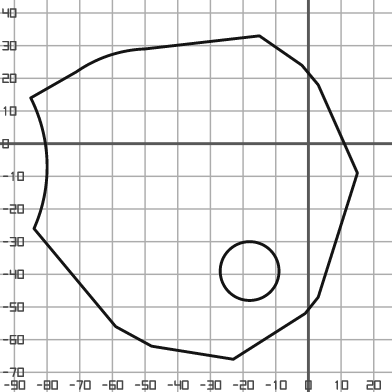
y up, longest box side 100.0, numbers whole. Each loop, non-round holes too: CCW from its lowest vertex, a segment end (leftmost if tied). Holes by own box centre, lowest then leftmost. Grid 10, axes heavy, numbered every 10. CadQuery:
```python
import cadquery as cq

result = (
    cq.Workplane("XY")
    .moveTo(-23.0, -66.0)
    .lineTo(-1.0, -52.0)
    .lineTo(3.0, -47.0)
    .lineTo(15.0, -9.0)
    .lineTo(3.0, 18.0)
    .lineTo(-2.0, 24.0)
    .lineTo(-15.0, 33.0)
    .lineTo(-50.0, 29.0)
    .threePointArc((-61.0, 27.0), (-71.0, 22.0))
    .lineTo(-85.0, 14.0)
    .threePointArc((-80.0, -6.0), (-84.0, -26.0))
    .lineTo(-59.0, -56.0)
    .lineTo(-48.0, -62.0)
    .close()
    .moveTo(-18.0, -39.0)
    .circle(9.0)
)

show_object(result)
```